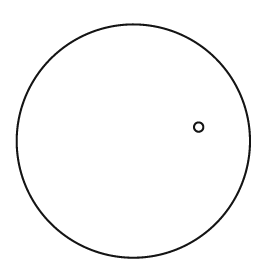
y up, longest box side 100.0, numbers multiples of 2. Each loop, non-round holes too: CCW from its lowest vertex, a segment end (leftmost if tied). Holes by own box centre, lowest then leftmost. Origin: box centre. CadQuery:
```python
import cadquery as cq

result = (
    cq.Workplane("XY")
    .moveTo(0.0, 0.0)
    .circle(50.0)
    .moveTo(28.0, 6.0)
    .circle(2.0)
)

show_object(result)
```